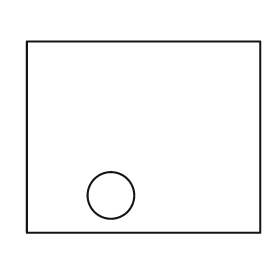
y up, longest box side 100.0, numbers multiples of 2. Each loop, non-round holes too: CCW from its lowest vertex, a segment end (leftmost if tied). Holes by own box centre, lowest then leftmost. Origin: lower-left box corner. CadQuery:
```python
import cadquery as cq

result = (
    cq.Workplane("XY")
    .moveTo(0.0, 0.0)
    .lineTo(100.0, 0.0)
    .lineTo(100.0, 82.0)
    .lineTo(0.0, 82.0)
    .close()
    .moveTo(36.0, 16.0)
    .circle(10.0)
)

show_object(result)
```